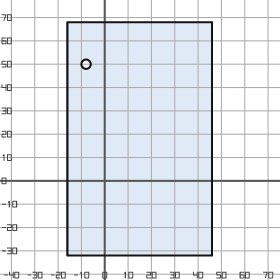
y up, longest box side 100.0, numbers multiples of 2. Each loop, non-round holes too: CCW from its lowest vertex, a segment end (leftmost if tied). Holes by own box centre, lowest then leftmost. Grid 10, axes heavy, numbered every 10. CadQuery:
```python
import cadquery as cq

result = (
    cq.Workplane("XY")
    .moveTo(-16.0, -32.0)
    .lineTo(46.0, -32.0)
    .lineTo(46.0, 68.0)
    .lineTo(-16.0, 68.0)
    .close()
    .moveTo(-8.0, 50.0)
    .circle(2.0)
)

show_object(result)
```